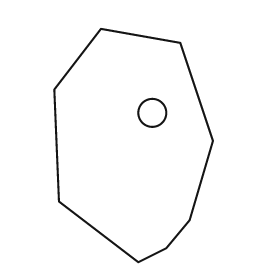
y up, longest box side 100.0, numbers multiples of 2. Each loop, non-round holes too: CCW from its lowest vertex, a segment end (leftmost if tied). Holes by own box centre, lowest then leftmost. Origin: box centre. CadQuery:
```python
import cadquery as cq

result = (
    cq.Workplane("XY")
    .moveTo(2.0, -50.0)
    .lineTo(14.0, -44.0)
    .lineTo(24.0, -32.0)
    .lineTo(34.0, 2.0)
    .lineTo(20.0, 44.0)
    .lineTo(-14.0, 50.0)
    .lineTo(-34.0, 24.0)
    .lineTo(-32.0, -24.0)
    .close()
    .moveTo(8.0, 14.0)
    .circle(6.0)
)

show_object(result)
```